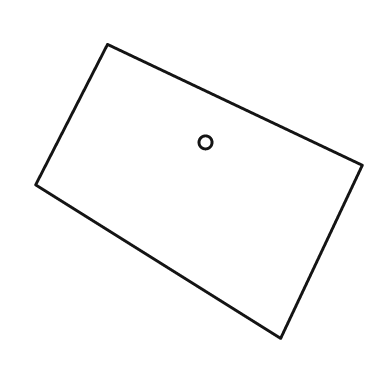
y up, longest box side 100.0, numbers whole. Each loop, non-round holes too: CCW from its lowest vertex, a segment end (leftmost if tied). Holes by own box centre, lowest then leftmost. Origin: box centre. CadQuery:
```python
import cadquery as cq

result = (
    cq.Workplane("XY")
    .moveTo(25.0, -45.0)
    .lineTo(50.0, 8.0)
    .lineTo(-28.0, 45.0)
    .lineTo(-50.0, 2.0)
    .close()
    .moveTo(2.0, 15.0)
    .circle(2.0)
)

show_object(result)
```